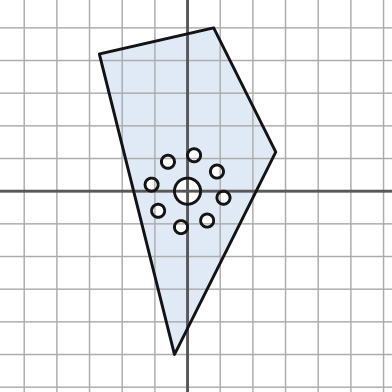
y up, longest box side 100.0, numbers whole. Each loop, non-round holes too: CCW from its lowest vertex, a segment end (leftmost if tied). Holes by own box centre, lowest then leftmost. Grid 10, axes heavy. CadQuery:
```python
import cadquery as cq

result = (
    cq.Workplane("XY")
    .moveTo(-4.0, -50.0)
    .lineTo(27.0, 12.0)
    .lineTo(8.0, 50.0)
    .lineTo(-27.0, 42.0)
    .close()
    .moveTo(-2.0, -11.0)
    .circle(2.0)
    .moveTo(6.0, -9.0)
    .circle(2.0)
    .moveTo(-9.0, -6.0)
    .circle(2.0)
    .moveTo(11.0, -2.0)
    .circle(2.0)
    .moveTo(0.0, 0.0)
    .circle(4.0)
    .moveTo(-11.0, 2.0)
    .circle(2.0)
    .moveTo(9.0, 6.0)
    .circle(2.0)
    .moveTo(-6.0, 9.0)
    .circle(2.0)
    .moveTo(2.0, 11.0)
    .circle(2.0)
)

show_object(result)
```